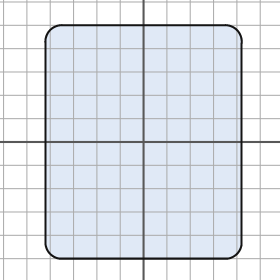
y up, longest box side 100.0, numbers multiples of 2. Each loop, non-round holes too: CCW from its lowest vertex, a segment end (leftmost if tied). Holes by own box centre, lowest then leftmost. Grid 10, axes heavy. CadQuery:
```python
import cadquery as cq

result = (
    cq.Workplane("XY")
    .moveTo(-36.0, -50.0)
    .lineTo(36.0, -50.0)
    .threePointArc((40.0, -48.0), (42.0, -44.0))
    .lineTo(42.0, 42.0)
    .threePointArc((40.0, 48.0), (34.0, 50.0))
    .lineTo(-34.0, 50.0)
    .threePointArc((-40.0, 48.0), (-42.0, 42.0))
    .lineTo(-42.0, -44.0)
    .threePointArc((-40.0, -48.0), (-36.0, -50.0))
    .close()
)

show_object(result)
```